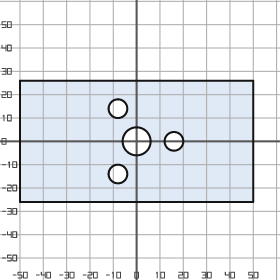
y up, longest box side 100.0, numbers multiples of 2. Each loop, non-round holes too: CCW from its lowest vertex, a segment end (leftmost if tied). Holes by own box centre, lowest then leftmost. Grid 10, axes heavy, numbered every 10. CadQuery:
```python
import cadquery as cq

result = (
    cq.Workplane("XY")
    .moveTo(-50.0, -26.0)
    .lineTo(50.0, -26.0)
    .lineTo(50.0, 26.0)
    .lineTo(-50.0, 26.0)
    .close()
    .moveTo(-8.0, -14.0)
    .circle(4.0)
    .moveTo(0.0, 0.0)
    .circle(6.0)
    .moveTo(16.0, 0.0)
    .circle(4.0)
    .moveTo(-8.0, 14.0)
    .circle(4.0)
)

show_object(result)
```